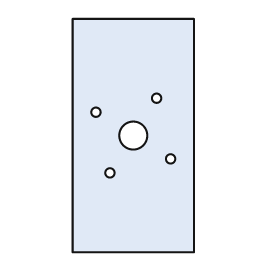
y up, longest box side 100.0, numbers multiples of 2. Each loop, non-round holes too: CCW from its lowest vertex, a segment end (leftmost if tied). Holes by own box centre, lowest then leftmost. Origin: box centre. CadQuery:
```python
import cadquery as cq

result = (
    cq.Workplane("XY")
    .moveTo(-26.0, -50.0)
    .lineTo(26.0, -50.0)
    .lineTo(26.0, 50.0)
    .lineTo(-26.0, 50.0)
    .close()
    .moveTo(-10.0, -16.0)
    .circle(2.0)
    .moveTo(16.0, -10.0)
    .circle(2.0)
    .moveTo(0.0, 0.0)
    .circle(6.0)
    .moveTo(-16.0, 10.0)
    .circle(2.0)
    .moveTo(10.0, 16.0)
    .circle(2.0)
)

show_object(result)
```